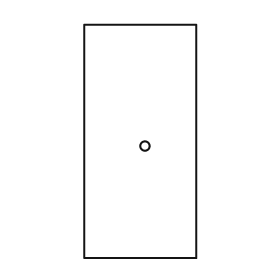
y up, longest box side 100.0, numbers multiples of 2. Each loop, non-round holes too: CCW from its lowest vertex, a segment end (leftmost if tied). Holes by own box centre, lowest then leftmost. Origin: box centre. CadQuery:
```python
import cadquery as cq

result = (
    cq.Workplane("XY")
    .moveTo(-24.0, -50.0)
    .lineTo(24.0, -50.0)
    .lineTo(24.0, 50.0)
    .lineTo(-24.0, 50.0)
    .close()
    .moveTo(2.0, -2.0)
    .circle(2.0)
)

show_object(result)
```